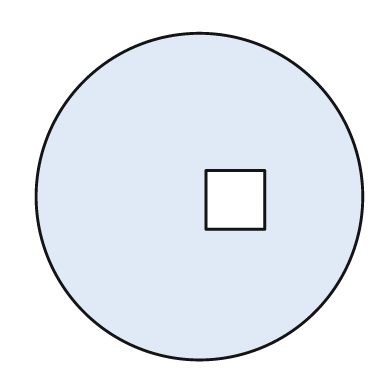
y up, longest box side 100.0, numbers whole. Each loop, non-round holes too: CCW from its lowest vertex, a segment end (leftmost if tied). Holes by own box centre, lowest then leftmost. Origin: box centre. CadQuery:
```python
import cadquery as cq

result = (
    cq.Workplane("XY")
    .moveTo(0.0, 0.0)
    .circle(50.0)
    .moveTo(2.0, -10.0)
    .lineTo(20.0, -10.0)
    .lineTo(20.0, 8.0)
    .lineTo(2.0, 8.0)
    .close()
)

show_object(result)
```